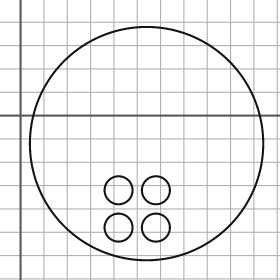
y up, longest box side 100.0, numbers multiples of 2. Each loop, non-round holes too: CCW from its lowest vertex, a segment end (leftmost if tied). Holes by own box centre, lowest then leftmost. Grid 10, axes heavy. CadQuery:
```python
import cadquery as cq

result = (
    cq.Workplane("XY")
    .moveTo(54.0, -12.0)
    .circle(50.0)
    .moveTo(42.0, -48.0)
    .circle(6.0)
    .moveTo(58.0, -48.0)
    .circle(6.0)
    .moveTo(42.0, -32.0)
    .circle(6.0)
    .moveTo(58.0, -32.0)
    .circle(6.0)
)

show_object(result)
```